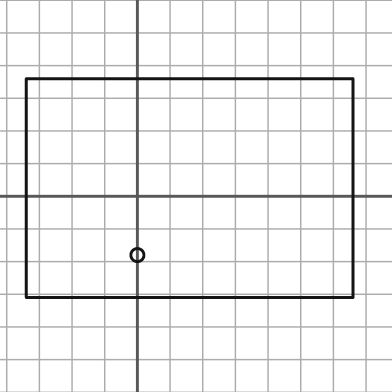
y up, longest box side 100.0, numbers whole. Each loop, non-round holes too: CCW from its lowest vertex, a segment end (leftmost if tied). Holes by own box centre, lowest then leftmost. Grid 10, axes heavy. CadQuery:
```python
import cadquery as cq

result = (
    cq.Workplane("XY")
    .moveTo(-34.0, -31.0)
    .lineTo(66.0, -31.0)
    .lineTo(66.0, 36.0)
    .lineTo(-34.0, 36.0)
    .close()
    .moveTo(0.0, -18.0)
    .circle(2.0)
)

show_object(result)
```